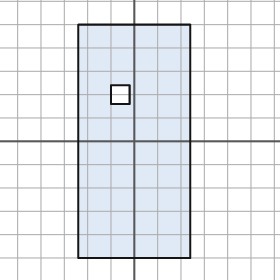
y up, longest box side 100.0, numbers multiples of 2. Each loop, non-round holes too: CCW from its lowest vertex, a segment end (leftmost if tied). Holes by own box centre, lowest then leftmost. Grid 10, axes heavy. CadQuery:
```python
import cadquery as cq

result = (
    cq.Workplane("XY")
    .moveTo(-24.0, -50.0)
    .lineTo(24.0, -50.0)
    .lineTo(24.0, 50.0)
    .lineTo(-24.0, 50.0)
    .close()
    .moveTo(-10.0, 16.0)
    .lineTo(-2.0, 16.0)
    .lineTo(-2.0, 24.0)
    .lineTo(-10.0, 24.0)
    .close()
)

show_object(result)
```